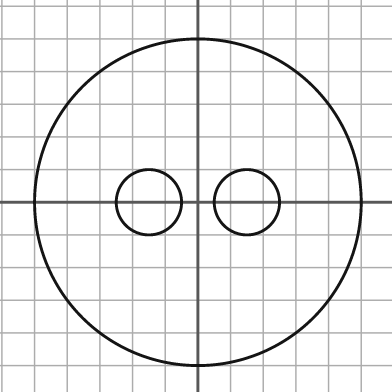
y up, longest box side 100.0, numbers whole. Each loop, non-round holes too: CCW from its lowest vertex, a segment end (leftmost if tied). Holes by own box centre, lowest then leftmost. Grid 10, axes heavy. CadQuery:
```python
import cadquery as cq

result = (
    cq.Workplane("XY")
    .moveTo(0.0, 0.0)
    .circle(50.0)
    .moveTo(-15.0, 0.0)
    .circle(10.0)
    .moveTo(15.0, 0.0)
    .circle(10.0)
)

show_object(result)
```